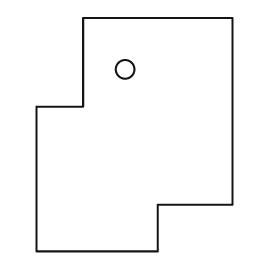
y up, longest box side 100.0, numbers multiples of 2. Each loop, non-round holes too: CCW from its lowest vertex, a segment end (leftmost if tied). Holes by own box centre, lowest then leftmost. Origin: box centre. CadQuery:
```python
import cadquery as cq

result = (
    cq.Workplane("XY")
    .moveTo(-42.0, -50.0)
    .lineTo(10.0, -50.0)
    .lineTo(10.0, -30.0)
    .lineTo(42.0, -30.0)
    .lineTo(42.0, 50.0)
    .lineTo(-22.0, 50.0)
    .lineTo(-22.0, 12.0)
    .lineTo(-42.0, 12.0)
    .close()
    .moveTo(-4.0, 28.0)
    .circle(4.0)
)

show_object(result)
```